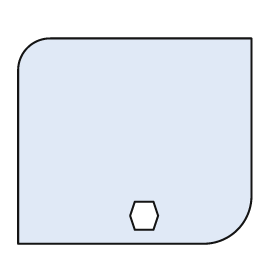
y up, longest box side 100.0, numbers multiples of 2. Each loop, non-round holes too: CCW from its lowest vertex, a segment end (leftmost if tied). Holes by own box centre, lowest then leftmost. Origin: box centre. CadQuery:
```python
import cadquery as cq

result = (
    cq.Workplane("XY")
    .moveTo(-50.0, -44.0)
    .lineTo(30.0, -44.0)
    .threePointArc((44.0, -38.0), (50.0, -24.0))
    .lineTo(50.0, 44.0)
    .lineTo(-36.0, 44.0)
    .threePointArc((-46.0, 40.0), (-50.0, 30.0))
    .close()
    .moveTo(0.0, -38.0)
    .lineTo(8.0, -38.0)
    .lineTo(10.0, -32.0)
    .lineTo(8.0, -26.0)
    .lineTo(0.0, -26.0)
    .lineTo(-2.0, -32.0)
    .close()
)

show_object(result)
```